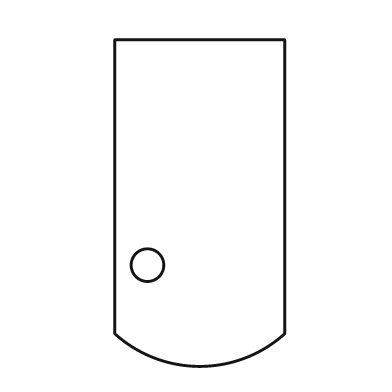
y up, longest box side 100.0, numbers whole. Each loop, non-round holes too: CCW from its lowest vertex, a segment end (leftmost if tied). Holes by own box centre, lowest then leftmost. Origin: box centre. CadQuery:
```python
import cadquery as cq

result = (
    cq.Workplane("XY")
    .moveTo(-26.0, -40.0)
    .threePointArc((0.0, -50.0), (26.0, -40.0))
    .lineTo(26.0, 50.0)
    .lineTo(-26.0, 50.0)
    .close()
    .moveTo(-16.0, -19.0)
    .circle(5.0)
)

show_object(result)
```